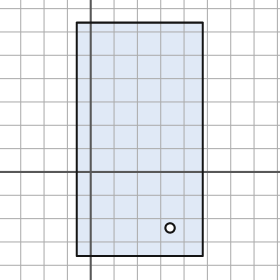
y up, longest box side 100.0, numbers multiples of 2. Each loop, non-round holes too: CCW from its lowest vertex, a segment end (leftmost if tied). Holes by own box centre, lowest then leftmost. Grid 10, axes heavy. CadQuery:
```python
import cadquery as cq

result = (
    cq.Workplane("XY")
    .moveTo(-6.0, -36.0)
    .lineTo(48.0, -36.0)
    .lineTo(48.0, 64.0)
    .lineTo(-6.0, 64.0)
    .close()
    .moveTo(34.0, -24.0)
    .circle(2.0)
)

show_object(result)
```